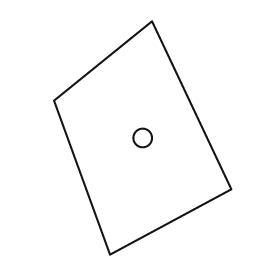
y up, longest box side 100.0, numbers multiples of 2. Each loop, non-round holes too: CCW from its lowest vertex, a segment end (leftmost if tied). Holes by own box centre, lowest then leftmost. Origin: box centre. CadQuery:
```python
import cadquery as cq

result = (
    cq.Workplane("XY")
    .moveTo(-14.0, -50.0)
    .lineTo(38.0, -22.0)
    .lineTo(4.0, 50.0)
    .lineTo(-38.0, 16.0)
    .close()
    .moveTo(0.0, 0.0)
    .circle(4.0)
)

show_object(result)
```